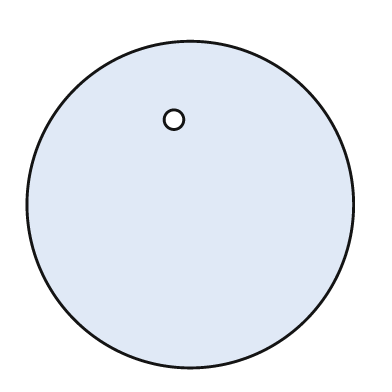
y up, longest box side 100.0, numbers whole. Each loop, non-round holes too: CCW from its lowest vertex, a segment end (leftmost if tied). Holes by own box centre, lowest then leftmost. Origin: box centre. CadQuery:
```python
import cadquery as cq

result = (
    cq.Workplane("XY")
    .moveTo(0.0, 0.0)
    .circle(50.0)
    .moveTo(-5.0, 26.0)
    .circle(3.0)
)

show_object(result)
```